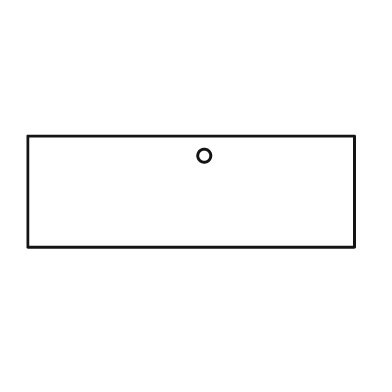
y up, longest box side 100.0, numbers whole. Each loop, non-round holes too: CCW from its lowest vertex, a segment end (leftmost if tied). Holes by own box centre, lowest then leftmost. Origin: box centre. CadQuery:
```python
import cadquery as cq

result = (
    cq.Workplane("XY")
    .moveTo(-50.0, -17.0)
    .lineTo(50.0, -17.0)
    .lineTo(50.0, 17.0)
    .lineTo(-50.0, 17.0)
    .close()
    .moveTo(4.0, 11.0)
    .circle(2.0)
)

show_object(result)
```